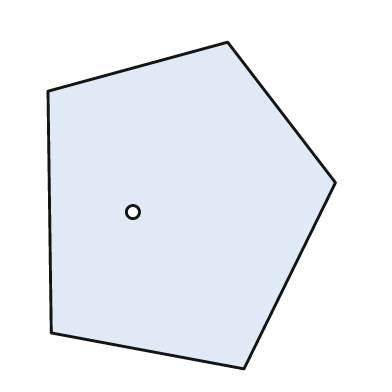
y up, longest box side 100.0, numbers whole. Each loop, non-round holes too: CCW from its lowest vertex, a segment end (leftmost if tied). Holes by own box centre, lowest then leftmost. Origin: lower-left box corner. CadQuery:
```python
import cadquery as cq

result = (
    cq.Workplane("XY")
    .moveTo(60.0, 0.0)
    .lineTo(88.0, 57.0)
    .lineTo(55.0, 100.0)
    .lineTo(0.0, 85.0)
    .lineTo(1.0, 11.0)
    .close()
    .moveTo(26.0, 48.0)
    .circle(2.0)
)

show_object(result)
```